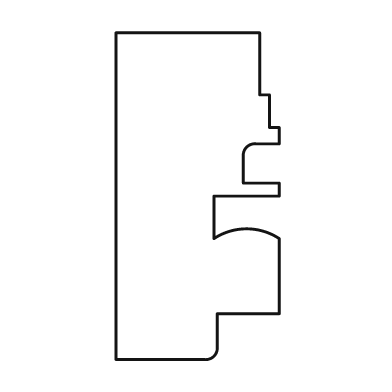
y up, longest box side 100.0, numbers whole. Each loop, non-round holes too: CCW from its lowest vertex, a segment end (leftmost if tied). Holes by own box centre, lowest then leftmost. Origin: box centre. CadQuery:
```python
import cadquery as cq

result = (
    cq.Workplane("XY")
    .moveTo(-25.0, -50.0)
    .lineTo(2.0, -50.0)
    .threePointArc((5.0, -49.0), (6.0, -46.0))
    .lineTo(6.0, -36.0)
    .lineTo(25.0, -36.0)
    .lineTo(25.0, -13.0)
    .threePointArc((15.0, -10.0), (5.0, -13.0))
    .lineTo(5.0, 0.0)
    .lineTo(25.0, 0.0)
    .lineTo(25.0, 4.0)
    .lineTo(14.0, 4.0)
    .lineTo(14.0, 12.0)
    .threePointArc((15.0, 15.0), (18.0, 16.0))
    .lineTo(25.0, 16.0)
    .lineTo(25.0, 21.0)
    .lineTo(22.0, 21.0)
    .lineTo(22.0, 31.0)
    .lineTo(19.0, 31.0)
    .lineTo(19.0, 50.0)
    .lineTo(-25.0, 50.0)
    .close()
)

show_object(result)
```